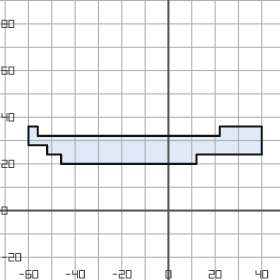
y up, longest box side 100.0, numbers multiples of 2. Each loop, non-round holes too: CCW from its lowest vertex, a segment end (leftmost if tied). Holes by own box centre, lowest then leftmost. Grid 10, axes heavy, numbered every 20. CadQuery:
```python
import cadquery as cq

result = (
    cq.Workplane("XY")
    .moveTo(-46.0, 20.0)
    .lineTo(12.0, 20.0)
    .lineTo(12.0, 24.0)
    .lineTo(40.0, 24.0)
    .lineTo(40.0, 36.0)
    .lineTo(22.0, 36.0)
    .lineTo(22.0, 32.0)
    .lineTo(-56.0, 32.0)
    .lineTo(-56.0, 36.0)
    .lineTo(-60.0, 36.0)
    .lineTo(-60.0, 28.0)
    .lineTo(-52.0, 28.0)
    .lineTo(-52.0, 24.0)
    .lineTo(-46.0, 24.0)
    .close()
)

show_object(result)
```